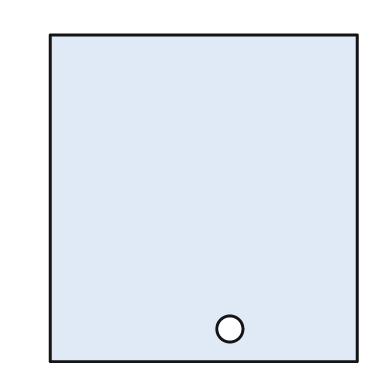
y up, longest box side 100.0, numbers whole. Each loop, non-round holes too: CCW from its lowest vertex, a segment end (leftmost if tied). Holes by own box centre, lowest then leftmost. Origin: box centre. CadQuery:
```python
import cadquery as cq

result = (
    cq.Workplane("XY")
    .moveTo(-47.0, -50.0)
    .lineTo(47.0, -50.0)
    .lineTo(47.0, 50.0)
    .lineTo(-47.0, 50.0)
    .close()
    .moveTo(8.0, -40.0)
    .circle(4.0)
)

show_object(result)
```